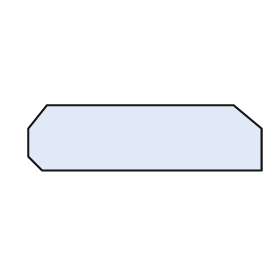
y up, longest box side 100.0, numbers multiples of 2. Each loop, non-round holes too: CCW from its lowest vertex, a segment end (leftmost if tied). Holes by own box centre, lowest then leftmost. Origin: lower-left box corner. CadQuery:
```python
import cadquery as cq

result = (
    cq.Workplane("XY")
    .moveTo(6.0, 0.0)
    .lineTo(100.0, 0.0)
    .lineTo(100.0, 18.0)
    .lineTo(88.0, 28.0)
    .lineTo(8.0, 28.0)
    .lineTo(0.0, 18.0)
    .lineTo(0.0, 6.0)
    .close()
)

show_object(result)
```